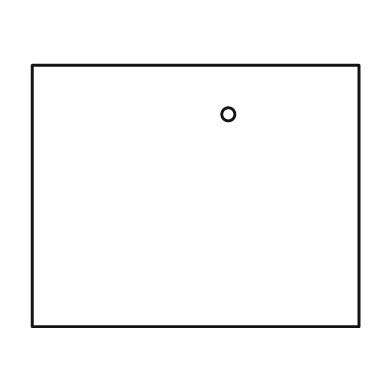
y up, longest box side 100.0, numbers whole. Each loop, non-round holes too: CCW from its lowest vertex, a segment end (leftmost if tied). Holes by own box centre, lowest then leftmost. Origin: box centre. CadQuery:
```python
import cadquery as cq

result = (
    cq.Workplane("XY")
    .moveTo(-50.0, -40.0)
    .lineTo(50.0, -40.0)
    .lineTo(50.0, 40.0)
    .lineTo(-50.0, 40.0)
    .close()
    .moveTo(10.0, 25.0)
    .circle(2.0)
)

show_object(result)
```